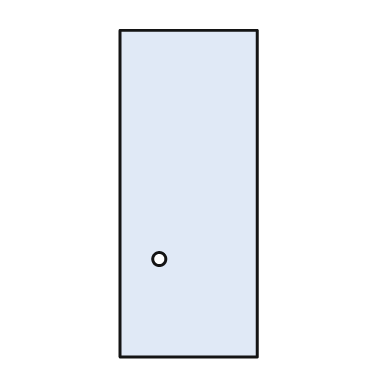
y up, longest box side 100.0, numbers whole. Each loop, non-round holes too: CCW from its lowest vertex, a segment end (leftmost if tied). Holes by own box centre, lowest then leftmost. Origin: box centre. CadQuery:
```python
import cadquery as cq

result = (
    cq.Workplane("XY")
    .moveTo(-21.0, -50.0)
    .lineTo(21.0, -50.0)
    .lineTo(21.0, 50.0)
    .lineTo(-21.0, 50.0)
    .close()
    .moveTo(-9.0, -20.0)
    .circle(2.0)
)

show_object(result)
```